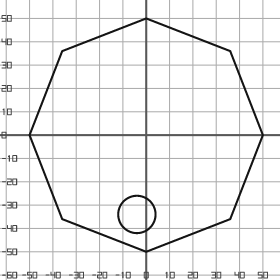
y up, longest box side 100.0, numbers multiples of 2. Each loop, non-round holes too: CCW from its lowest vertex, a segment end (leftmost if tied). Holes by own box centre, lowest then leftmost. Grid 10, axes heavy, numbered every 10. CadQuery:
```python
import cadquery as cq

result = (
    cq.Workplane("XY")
    .moveTo(0.0, -50.0)
    .lineTo(36.0, -36.0)
    .lineTo(50.0, 0.0)
    .lineTo(36.0, 36.0)
    .lineTo(0.0, 50.0)
    .lineTo(-36.0, 36.0)
    .lineTo(-50.0, 0.0)
    .lineTo(-36.0, -36.0)
    .close()
    .moveTo(-4.0, -34.0)
    .circle(8.0)
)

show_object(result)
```